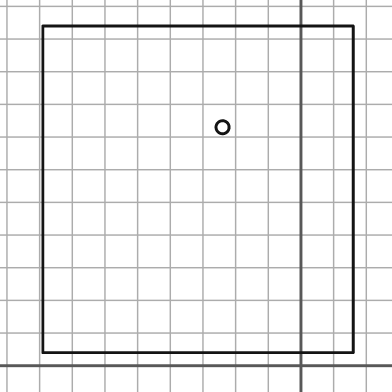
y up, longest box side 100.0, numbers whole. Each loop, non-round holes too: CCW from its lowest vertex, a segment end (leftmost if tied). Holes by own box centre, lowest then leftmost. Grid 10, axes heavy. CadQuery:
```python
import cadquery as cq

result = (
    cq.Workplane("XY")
    .moveTo(-79.0, 4.0)
    .lineTo(16.0, 4.0)
    .lineTo(16.0, 104.0)
    .lineTo(-79.0, 104.0)
    .close()
    .moveTo(-24.0, 73.0)
    .circle(2.0)
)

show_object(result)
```